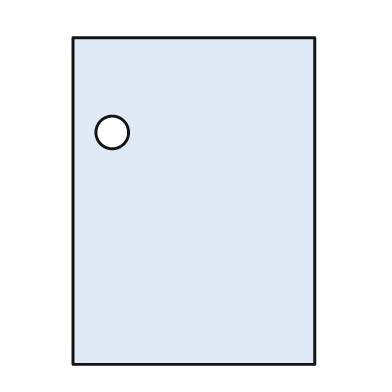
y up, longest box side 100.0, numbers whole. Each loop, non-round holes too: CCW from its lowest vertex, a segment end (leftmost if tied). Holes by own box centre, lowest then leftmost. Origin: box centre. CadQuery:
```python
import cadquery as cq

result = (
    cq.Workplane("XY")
    .moveTo(-37.0, -50.0)
    .lineTo(37.0, -50.0)
    .lineTo(37.0, 50.0)
    .lineTo(-37.0, 50.0)
    .close()
    .moveTo(-25.0, 21.0)
    .circle(5.0)
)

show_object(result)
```